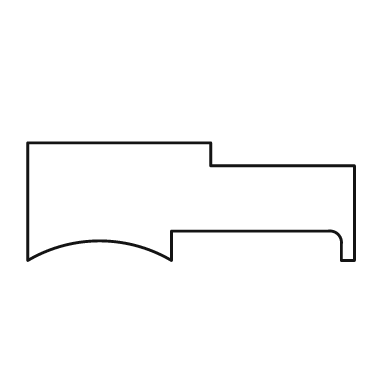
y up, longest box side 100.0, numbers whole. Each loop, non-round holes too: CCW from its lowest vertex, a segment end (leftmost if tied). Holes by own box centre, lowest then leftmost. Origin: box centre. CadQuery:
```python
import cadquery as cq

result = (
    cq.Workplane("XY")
    .moveTo(-50.0, -18.0)
    .threePointArc((-28.0, -12.0), (-6.0, -18.0))
    .lineTo(-6.0, -9.0)
    .lineTo(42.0, -9.0)
    .threePointArc((45.0, -10.0), (46.0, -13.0))
    .lineTo(46.0, -18.0)
    .lineTo(50.0, -18.0)
    .lineTo(50.0, 11.0)
    .lineTo(6.0, 11.0)
    .lineTo(6.0, 18.0)
    .lineTo(-50.0, 18.0)
    .close()
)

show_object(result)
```